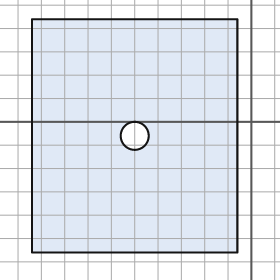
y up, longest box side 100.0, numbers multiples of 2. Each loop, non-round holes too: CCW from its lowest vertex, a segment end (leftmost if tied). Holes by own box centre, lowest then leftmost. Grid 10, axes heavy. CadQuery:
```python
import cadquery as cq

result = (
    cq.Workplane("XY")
    .moveTo(-94.0, -56.0)
    .lineTo(-6.0, -56.0)
    .lineTo(-6.0, 44.0)
    .lineTo(-94.0, 44.0)
    .close()
    .moveTo(-50.0, -6.0)
    .circle(6.0)
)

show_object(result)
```